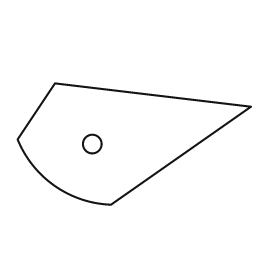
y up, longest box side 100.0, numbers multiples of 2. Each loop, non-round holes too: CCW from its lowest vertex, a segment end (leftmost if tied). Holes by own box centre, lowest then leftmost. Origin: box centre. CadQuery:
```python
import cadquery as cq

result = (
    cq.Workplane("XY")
    .moveTo(-10.0, -26.0)
    .lineTo(50.0, 16.0)
    .lineTo(-34.0, 26.0)
    .lineTo(-50.0, 2.0)
    .threePointArc((-34.0, -18.0), (-10.0, -26.0))
    .close()
    .moveTo(-18.0, 0.0)
    .circle(4.0)
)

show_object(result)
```